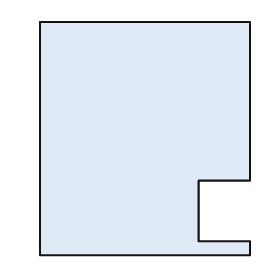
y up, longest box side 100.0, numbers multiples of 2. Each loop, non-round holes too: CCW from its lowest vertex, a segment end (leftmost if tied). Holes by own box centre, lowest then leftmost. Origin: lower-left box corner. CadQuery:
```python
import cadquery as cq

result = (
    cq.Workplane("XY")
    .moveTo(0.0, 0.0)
    .lineTo(90.0, 0.0)
    .lineTo(90.0, 6.0)
    .lineTo(68.0, 6.0)
    .lineTo(68.0, 32.0)
    .lineTo(90.0, 32.0)
    .lineTo(90.0, 100.0)
    .lineTo(0.0, 100.0)
    .close()
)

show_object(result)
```